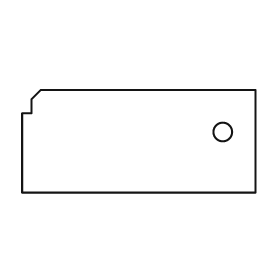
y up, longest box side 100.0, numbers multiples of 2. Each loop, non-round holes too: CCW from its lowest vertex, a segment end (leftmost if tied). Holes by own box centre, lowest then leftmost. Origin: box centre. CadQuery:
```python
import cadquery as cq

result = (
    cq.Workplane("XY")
    .moveTo(-50.0, -22.0)
    .lineTo(50.0, -22.0)
    .lineTo(50.0, 22.0)
    .lineTo(-42.0, 22.0)
    .lineTo(-46.0, 18.0)
    .lineTo(-46.0, 12.0)
    .lineTo(-50.0, 12.0)
    .close()
    .moveTo(36.0, 4.0)
    .circle(4.0)
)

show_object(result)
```